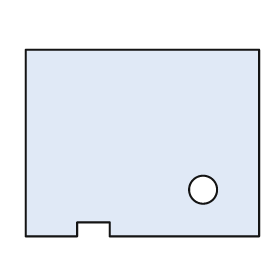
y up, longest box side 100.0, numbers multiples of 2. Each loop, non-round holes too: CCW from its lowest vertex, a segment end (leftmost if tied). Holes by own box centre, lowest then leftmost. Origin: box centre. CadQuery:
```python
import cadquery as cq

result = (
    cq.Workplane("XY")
    .moveTo(-50.0, -40.0)
    .lineTo(-28.0, -40.0)
    .lineTo(-28.0, -34.0)
    .lineTo(-14.0, -34.0)
    .lineTo(-14.0, -40.0)
    .lineTo(50.0, -40.0)
    .lineTo(50.0, 40.0)
    .lineTo(-50.0, 40.0)
    .close()
    .moveTo(26.0, -20.0)
    .circle(6.0)
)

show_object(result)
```